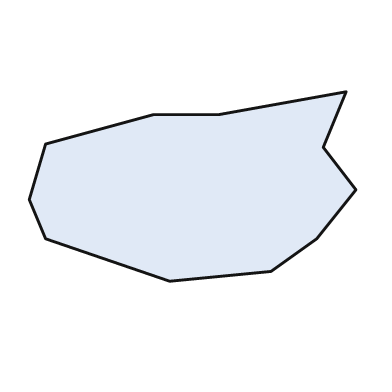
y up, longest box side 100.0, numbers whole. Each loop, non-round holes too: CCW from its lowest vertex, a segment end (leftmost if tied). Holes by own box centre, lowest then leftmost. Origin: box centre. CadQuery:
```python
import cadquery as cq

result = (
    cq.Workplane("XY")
    .moveTo(-7.0, -29.0)
    .lineTo(24.0, -26.0)
    .lineTo(38.0, -16.0)
    .lineTo(50.0, -1.0)
    .lineTo(40.0, 12.0)
    .lineTo(47.0, 29.0)
    .lineTo(8.0, 22.0)
    .lineTo(-12.0, 22.0)
    .lineTo(-45.0, 13.0)
    .lineTo(-50.0, -4.0)
    .lineTo(-45.0, -16.0)
    .close()
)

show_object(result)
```